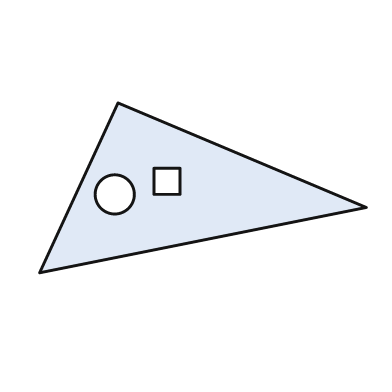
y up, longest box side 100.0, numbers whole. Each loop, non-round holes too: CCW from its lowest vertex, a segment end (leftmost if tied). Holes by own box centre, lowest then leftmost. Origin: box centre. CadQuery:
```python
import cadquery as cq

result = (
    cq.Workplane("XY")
    .moveTo(-50.0, -26.0)
    .lineTo(50.0, -6.0)
    .lineTo(-26.0, 26.0)
    .close()
    .moveTo(-27.0, -2.0)
    .circle(6.0)
    .moveTo(-15.0, -2.0)
    .lineTo(-7.0, -2.0)
    .lineTo(-7.0, 6.0)
    .lineTo(-15.0, 6.0)
    .close()
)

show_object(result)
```